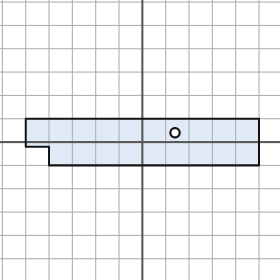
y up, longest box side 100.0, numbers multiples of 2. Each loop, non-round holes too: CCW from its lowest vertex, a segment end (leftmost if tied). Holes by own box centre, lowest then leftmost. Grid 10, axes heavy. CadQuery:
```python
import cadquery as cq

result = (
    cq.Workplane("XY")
    .moveTo(-40.0, -10.0)
    .lineTo(50.0, -10.0)
    .lineTo(50.0, 10.0)
    .lineTo(-50.0, 10.0)
    .lineTo(-50.0, -2.0)
    .lineTo(-40.0, -2.0)
    .close()
    .moveTo(14.0, 4.0)
    .circle(2.0)
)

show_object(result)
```